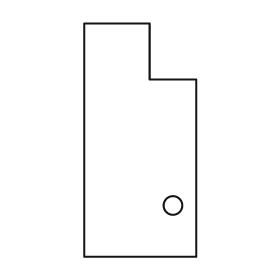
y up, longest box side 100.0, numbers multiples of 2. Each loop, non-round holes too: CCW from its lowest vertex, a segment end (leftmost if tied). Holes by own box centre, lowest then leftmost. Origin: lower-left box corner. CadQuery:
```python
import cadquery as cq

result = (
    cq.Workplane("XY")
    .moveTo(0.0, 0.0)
    .lineTo(48.0, 0.0)
    .lineTo(48.0, 76.0)
    .lineTo(28.0, 76.0)
    .lineTo(28.0, 100.0)
    .lineTo(0.0, 100.0)
    .close()
    .moveTo(38.0, 22.0)
    .circle(4.0)
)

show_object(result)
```